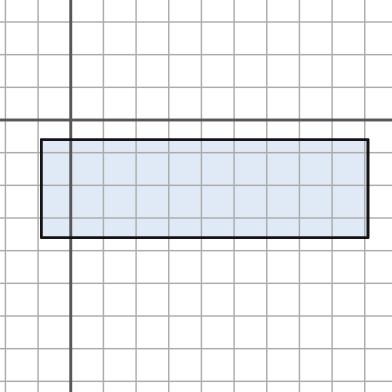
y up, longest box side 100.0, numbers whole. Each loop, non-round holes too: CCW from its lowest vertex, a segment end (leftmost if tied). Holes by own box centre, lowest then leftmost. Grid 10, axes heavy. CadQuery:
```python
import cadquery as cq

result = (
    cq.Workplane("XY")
    .moveTo(-9.0, -36.0)
    .lineTo(91.0, -36.0)
    .lineTo(91.0, -6.0)
    .lineTo(-9.0, -6.0)
    .close()
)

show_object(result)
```